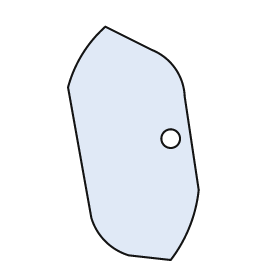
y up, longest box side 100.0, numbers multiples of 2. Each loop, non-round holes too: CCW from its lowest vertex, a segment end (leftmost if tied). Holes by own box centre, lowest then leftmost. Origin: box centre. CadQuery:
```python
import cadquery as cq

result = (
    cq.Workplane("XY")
    .moveTo(16.0, -50.0)
    .threePointArc((24.0, -36.0), (28.0, -20.0))
    .lineTo(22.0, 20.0)
    .threePointArc((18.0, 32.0), (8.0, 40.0))
    .lineTo(-12.0, 50.0)
    .threePointArc((-22.0, 38.0), (-28.0, 24.0))
    .lineTo(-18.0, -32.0)
    .threePointArc((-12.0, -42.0), (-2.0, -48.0))
    .close()
    .moveTo(16.0, 2.0)
    .circle(4.0)
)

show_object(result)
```